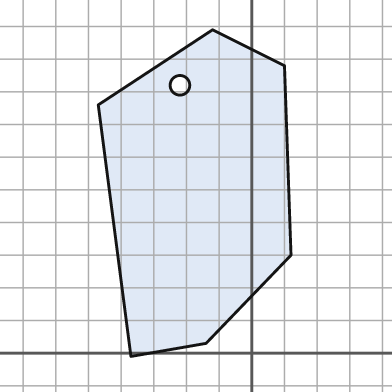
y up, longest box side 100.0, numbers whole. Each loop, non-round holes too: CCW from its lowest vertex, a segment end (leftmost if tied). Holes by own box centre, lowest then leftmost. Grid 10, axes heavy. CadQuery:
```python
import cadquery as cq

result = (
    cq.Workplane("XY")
    .moveTo(-37.0, -1.0)
    .lineTo(-14.0, 3.0)
    .lineTo(12.0, 30.0)
    .lineTo(10.0, 88.0)
    .lineTo(-12.0, 99.0)
    .lineTo(-47.0, 76.0)
    .close()
    .moveTo(-22.0, 82.0)
    .circle(3.0)
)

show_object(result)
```